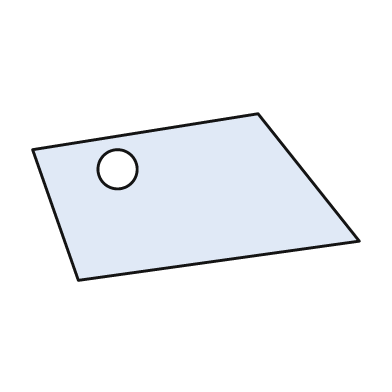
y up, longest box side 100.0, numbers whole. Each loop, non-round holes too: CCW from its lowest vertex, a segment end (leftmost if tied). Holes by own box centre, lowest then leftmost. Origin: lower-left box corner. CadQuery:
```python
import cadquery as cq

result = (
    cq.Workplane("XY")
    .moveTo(14.0, 0.0)
    .lineTo(100.0, 12.0)
    .lineTo(69.0, 51.0)
    .lineTo(0.0, 40.0)
    .close()
    .moveTo(26.0, 34.0)
    .circle(6.0)
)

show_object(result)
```